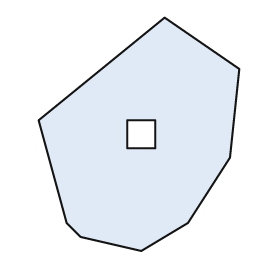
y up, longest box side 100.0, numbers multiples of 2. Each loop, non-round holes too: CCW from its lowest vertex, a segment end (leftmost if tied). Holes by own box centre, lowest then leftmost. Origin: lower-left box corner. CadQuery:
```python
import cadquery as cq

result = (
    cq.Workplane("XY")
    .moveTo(44.0, 0.0)
    .lineTo(64.0, 12.0)
    .lineTo(82.0, 40.0)
    .lineTo(86.0, 78.0)
    .lineTo(54.0, 100.0)
    .lineTo(0.0, 56.0)
    .lineTo(12.0, 12.0)
    .lineTo(18.0, 6.0)
    .close()
    .moveTo(38.0, 44.0)
    .lineTo(50.0, 44.0)
    .lineTo(50.0, 56.0)
    .lineTo(38.0, 56.0)
    .close()
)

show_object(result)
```